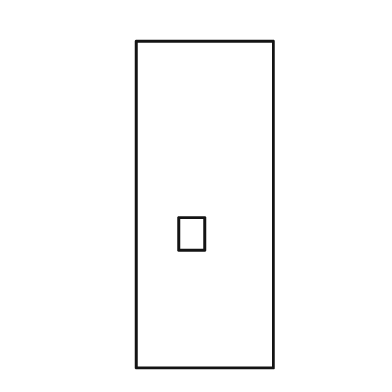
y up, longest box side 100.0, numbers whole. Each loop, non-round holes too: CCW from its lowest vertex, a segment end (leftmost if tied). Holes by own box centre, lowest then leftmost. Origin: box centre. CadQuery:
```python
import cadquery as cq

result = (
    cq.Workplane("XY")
    .moveTo(-21.0, -50.0)
    .lineTo(21.0, -50.0)
    .lineTo(21.0, 50.0)
    .lineTo(-21.0, 50.0)
    .close()
    .moveTo(-8.0, -14.0)
    .lineTo(0.0, -14.0)
    .lineTo(0.0, -4.0)
    .lineTo(-8.0, -4.0)
    .close()
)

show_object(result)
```